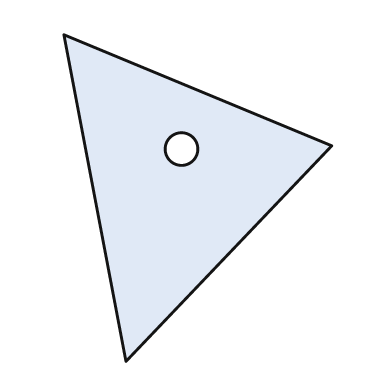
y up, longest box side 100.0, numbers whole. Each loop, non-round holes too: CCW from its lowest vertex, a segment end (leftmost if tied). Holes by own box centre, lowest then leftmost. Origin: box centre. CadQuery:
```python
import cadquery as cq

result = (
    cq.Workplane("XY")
    .moveTo(-22.0, -50.0)
    .lineTo(41.0, 16.0)
    .lineTo(-41.0, 50.0)
    .close()
    .moveTo(-5.0, 15.0)
    .circle(5.0)
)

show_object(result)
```